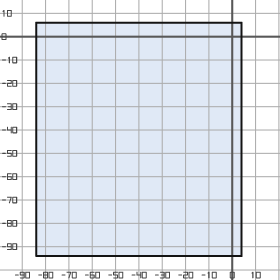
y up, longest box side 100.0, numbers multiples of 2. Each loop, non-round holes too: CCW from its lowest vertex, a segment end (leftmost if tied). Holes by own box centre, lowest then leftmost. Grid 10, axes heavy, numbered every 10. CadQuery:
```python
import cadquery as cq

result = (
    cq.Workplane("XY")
    .moveTo(-84.0, -94.0)
    .lineTo(4.0, -94.0)
    .lineTo(4.0, 6.0)
    .lineTo(-84.0, 6.0)
    .close()
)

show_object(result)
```